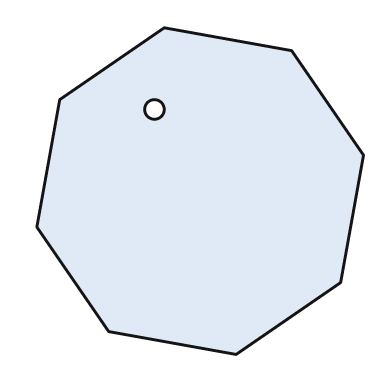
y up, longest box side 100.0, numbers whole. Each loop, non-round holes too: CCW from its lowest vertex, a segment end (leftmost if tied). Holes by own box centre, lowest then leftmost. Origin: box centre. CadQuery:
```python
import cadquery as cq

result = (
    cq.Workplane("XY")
    .moveTo(11.0, -50.0)
    .lineTo(43.0, -28.0)
    .lineTo(50.0, 11.0)
    .lineTo(28.0, 43.0)
    .lineTo(-11.0, 50.0)
    .lineTo(-43.0, 28.0)
    .lineTo(-50.0, -11.0)
    .lineTo(-28.0, -43.0)
    .close()
    .moveTo(-14.0, 25.0)
    .circle(3.0)
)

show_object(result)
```